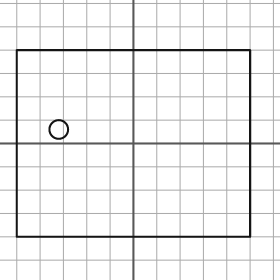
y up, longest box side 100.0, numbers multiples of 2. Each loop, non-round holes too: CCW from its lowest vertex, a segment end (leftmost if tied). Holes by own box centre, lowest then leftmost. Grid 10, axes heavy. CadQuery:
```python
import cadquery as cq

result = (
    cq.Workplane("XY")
    .moveTo(-50.0, -40.0)
    .lineTo(50.0, -40.0)
    .lineTo(50.0, 40.0)
    .lineTo(-50.0, 40.0)
    .close()
    .moveTo(-32.0, 6.0)
    .circle(4.0)
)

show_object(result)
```